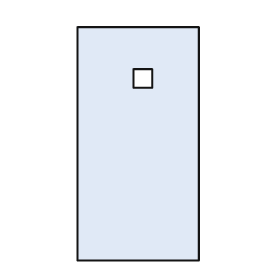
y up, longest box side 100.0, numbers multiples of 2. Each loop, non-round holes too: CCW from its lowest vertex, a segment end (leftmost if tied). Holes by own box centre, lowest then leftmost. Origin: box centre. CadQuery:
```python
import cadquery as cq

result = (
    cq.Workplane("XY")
    .moveTo(-26.0, -50.0)
    .lineTo(26.0, -50.0)
    .lineTo(26.0, 50.0)
    .lineTo(-26.0, 50.0)
    .close()
    .moveTo(-2.0, 24.0)
    .lineTo(6.0, 24.0)
    .lineTo(6.0, 32.0)
    .lineTo(-2.0, 32.0)
    .close()
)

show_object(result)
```